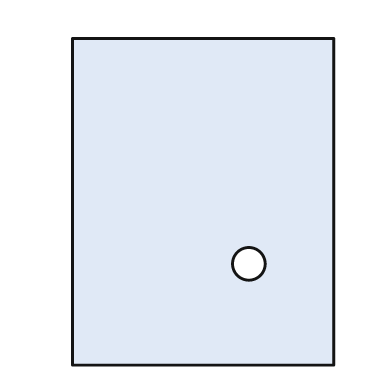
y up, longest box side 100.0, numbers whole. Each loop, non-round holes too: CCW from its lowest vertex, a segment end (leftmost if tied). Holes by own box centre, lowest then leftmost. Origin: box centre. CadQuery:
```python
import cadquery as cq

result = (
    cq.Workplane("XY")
    .moveTo(-40.0, -50.0)
    .lineTo(40.0, -50.0)
    .lineTo(40.0, 50.0)
    .lineTo(-40.0, 50.0)
    .close()
    .moveTo(14.0, -19.0)
    .circle(5.0)
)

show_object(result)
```